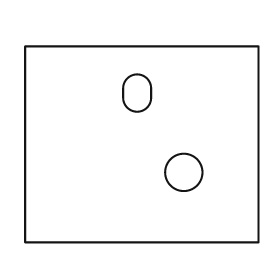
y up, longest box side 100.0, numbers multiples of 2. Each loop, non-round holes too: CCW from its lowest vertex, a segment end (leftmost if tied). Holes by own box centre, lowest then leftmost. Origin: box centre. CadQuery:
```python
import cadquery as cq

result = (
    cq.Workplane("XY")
    .moveTo(-50.0, -42.0)
    .lineTo(50.0, -42.0)
    .lineTo(50.0, 42.0)
    .lineTo(-50.0, 42.0)
    .close()
    .moveTo(18.0, -12.0)
    .circle(8.0)
    .moveTo(-8.0, 20.0)
    .threePointArc((-2.0, 14.0), (4.0, 20.0))
    .lineTo(4.0, 24.0)
    .threePointArc((-2.0, 30.0), (-8.0, 24.0))
    .close()
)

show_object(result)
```